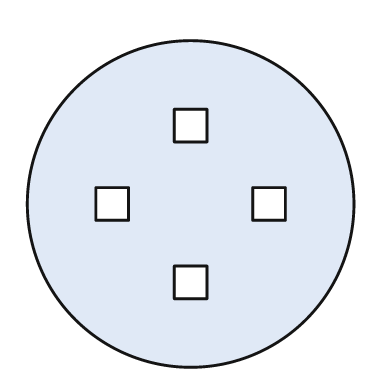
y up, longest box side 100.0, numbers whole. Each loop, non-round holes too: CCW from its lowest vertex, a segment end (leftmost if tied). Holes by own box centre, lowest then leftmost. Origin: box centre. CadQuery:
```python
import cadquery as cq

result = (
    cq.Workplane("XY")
    .moveTo(0.0, 0.0)
    .circle(50.0)
    .moveTo(-5.0, -29.0)
    .lineTo(5.0, -29.0)
    .lineTo(5.0, -19.0)
    .lineTo(-5.0, -19.0)
    .close()
    .moveTo(-29.0, -5.0)
    .lineTo(-19.0, -5.0)
    .lineTo(-19.0, 5.0)
    .lineTo(-29.0, 5.0)
    .close()
    .moveTo(19.0, -5.0)
    .lineTo(29.0, -5.0)
    .lineTo(29.0, 5.0)
    .lineTo(19.0, 5.0)
    .close()
    .moveTo(-5.0, 19.0)
    .lineTo(5.0, 19.0)
    .lineTo(5.0, 29.0)
    .lineTo(-5.0, 29.0)
    .close()
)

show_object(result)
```